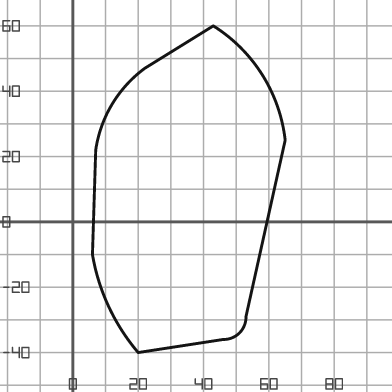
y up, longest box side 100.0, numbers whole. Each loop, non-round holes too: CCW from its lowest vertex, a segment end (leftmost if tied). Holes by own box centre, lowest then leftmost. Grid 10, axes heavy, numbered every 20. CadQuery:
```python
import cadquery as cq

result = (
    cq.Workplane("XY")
    .moveTo(20.0, -40.0)
    .lineTo(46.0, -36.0)
    .threePointArc((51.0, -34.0), (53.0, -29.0))
    .lineTo(65.0, 25.0)
    .threePointArc((58.0, 45.0), (43.0, 60.0))
    .lineTo(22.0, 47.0)
    .threePointArc((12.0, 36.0), (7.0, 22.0))
    .lineTo(6.0, -10.0)
    .threePointArc((11.0, -26.0), (20.0, -40.0))
    .close()
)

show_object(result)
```